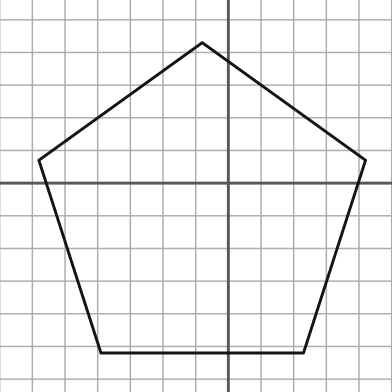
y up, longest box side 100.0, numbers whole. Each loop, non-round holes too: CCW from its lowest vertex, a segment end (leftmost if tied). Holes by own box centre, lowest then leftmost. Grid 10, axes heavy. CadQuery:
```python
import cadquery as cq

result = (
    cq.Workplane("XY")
    .moveTo(-39.0, -52.0)
    .lineTo(23.0, -52.0)
    .lineTo(42.0, 7.0)
    .lineTo(-8.0, 43.0)
    .lineTo(-58.0, 7.0)
    .close()
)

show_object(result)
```